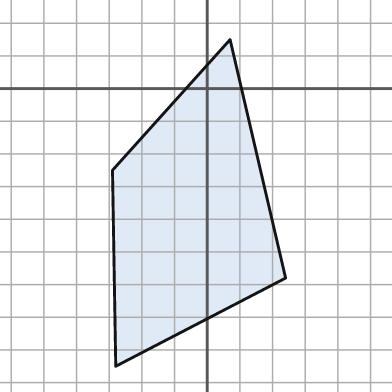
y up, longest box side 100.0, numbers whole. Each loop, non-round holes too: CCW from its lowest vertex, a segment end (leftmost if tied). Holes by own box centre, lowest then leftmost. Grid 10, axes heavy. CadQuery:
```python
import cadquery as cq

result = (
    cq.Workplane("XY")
    .moveTo(-28.0, -85.0)
    .lineTo(24.0, -58.0)
    .lineTo(7.0, 15.0)
    .lineTo(-29.0, -25.0)
    .close()
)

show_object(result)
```